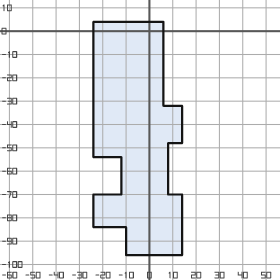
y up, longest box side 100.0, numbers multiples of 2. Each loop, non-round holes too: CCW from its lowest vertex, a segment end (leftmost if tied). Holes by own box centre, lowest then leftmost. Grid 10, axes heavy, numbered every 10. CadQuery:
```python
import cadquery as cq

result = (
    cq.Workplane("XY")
    .moveTo(-10.0, -96.0)
    .lineTo(14.0, -96.0)
    .lineTo(14.0, -70.0)
    .lineTo(8.0, -70.0)
    .lineTo(8.0, -48.0)
    .lineTo(14.0, -48.0)
    .lineTo(14.0, -32.0)
    .lineTo(6.0, -32.0)
    .lineTo(6.0, 4.0)
    .lineTo(-24.0, 4.0)
    .lineTo(-24.0, -54.0)
    .lineTo(-12.0, -54.0)
    .lineTo(-12.0, -70.0)
    .lineTo(-24.0, -70.0)
    .lineTo(-24.0, -84.0)
    .lineTo(-10.0, -84.0)
    .close()
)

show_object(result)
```